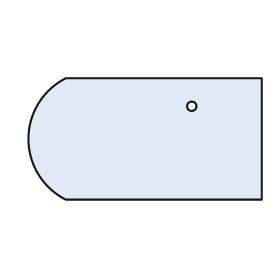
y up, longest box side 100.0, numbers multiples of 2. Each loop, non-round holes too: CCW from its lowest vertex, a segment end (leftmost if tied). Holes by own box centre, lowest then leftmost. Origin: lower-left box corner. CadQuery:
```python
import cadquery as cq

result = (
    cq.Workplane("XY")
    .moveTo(16.0, 0.0)
    .lineTo(100.0, 0.0)
    .lineTo(100.0, 52.0)
    .lineTo(16.0, 52.0)
    .threePointArc((0.0, 26.0), (16.0, 0.0))
    .close()
    .moveTo(70.0, 40.0)
    .circle(2.0)
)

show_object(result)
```